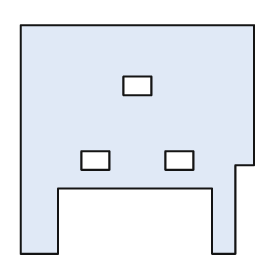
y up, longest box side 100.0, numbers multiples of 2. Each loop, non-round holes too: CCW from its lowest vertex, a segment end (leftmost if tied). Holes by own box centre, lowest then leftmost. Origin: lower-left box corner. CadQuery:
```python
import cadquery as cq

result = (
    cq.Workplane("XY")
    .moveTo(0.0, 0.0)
    .lineTo(16.0, 0.0)
    .lineTo(16.0, 28.0)
    .lineTo(82.0, 28.0)
    .lineTo(82.0, 0.0)
    .lineTo(92.0, 0.0)
    .lineTo(92.0, 38.0)
    .lineTo(100.0, 38.0)
    .lineTo(100.0, 98.0)
    .lineTo(0.0, 98.0)
    .close()
    .moveTo(26.0, 36.0)
    .lineTo(38.0, 36.0)
    .lineTo(38.0, 44.0)
    .lineTo(26.0, 44.0)
    .close()
    .moveTo(62.0, 36.0)
    .lineTo(74.0, 36.0)
    .lineTo(74.0, 44.0)
    .lineTo(62.0, 44.0)
    .close()
    .moveTo(44.0, 68.0)
    .lineTo(56.0, 68.0)
    .lineTo(56.0, 76.0)
    .lineTo(44.0, 76.0)
    .close()
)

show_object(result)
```